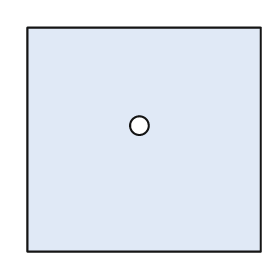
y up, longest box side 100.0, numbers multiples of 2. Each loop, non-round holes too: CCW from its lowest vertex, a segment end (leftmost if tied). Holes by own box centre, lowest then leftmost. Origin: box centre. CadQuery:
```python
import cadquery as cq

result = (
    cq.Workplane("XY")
    .moveTo(-50.0, -48.0)
    .lineTo(50.0, -48.0)
    .lineTo(50.0, 48.0)
    .lineTo(-50.0, 48.0)
    .close()
    .moveTo(-2.0, 6.0)
    .circle(4.0)
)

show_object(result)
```